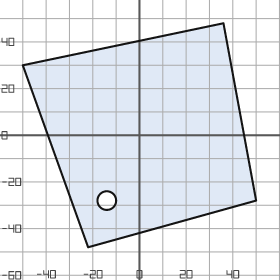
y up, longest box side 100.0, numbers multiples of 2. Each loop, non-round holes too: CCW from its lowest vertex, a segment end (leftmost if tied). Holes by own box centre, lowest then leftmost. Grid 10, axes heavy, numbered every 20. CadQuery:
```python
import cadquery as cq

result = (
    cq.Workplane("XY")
    .moveTo(-22.0, -48.0)
    .lineTo(50.0, -28.0)
    .lineTo(36.0, 48.0)
    .lineTo(-50.0, 30.0)
    .close()
    .moveTo(-14.0, -28.0)
    .circle(4.0)
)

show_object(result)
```